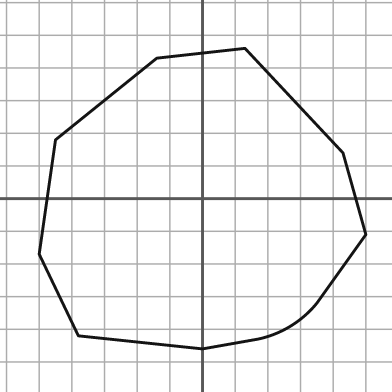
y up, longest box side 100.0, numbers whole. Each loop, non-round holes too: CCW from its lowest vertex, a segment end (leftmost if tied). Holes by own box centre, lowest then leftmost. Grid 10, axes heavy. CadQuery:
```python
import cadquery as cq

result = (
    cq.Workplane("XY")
    .moveTo(0.0, -46.0)
    .lineTo(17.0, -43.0)
    .threePointArc((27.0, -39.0), (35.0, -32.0))
    .lineTo(50.0, -11.0)
    .lineTo(43.0, 14.0)
    .lineTo(13.0, 46.0)
    .lineTo(-14.0, 43.0)
    .lineTo(-45.0, 18.0)
    .lineTo(-50.0, -17.0)
    .lineTo(-38.0, -42.0)
    .close()
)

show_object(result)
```